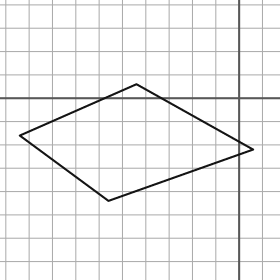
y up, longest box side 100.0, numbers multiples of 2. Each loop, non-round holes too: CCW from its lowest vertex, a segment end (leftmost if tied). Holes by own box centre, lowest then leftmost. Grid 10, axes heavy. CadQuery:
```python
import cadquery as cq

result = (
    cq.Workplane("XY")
    .moveTo(-56.0, -44.0)
    .lineTo(6.0, -22.0)
    .lineTo(-44.0, 6.0)
    .lineTo(-94.0, -16.0)
    .close()
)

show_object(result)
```